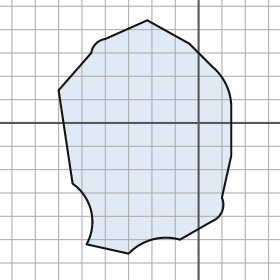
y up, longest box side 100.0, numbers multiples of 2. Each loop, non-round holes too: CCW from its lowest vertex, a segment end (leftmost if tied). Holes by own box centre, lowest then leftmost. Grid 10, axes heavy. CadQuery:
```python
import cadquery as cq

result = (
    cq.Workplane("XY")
    .moveTo(-30.0, -56.0)
    .threePointArc((-20.0, -50.0), (-8.0, -50.0))
    .lineTo(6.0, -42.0)
    .threePointArc((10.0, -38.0), (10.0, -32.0))
    .lineTo(14.0, -14.0)
    .lineTo(14.0, 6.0)
    .threePointArc((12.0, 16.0), (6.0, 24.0))
    .lineTo(-4.0, 34.0)
    .lineTo(-22.0, 44.0)
    .lineTo(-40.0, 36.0)
    .threePointArc((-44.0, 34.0), (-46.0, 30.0))
    .lineTo(-60.0, 14.0)
    .lineTo(-54.0, -26.0)
    .threePointArc((-46.0, -38.0), (-48.0, -52.0))
    .close()
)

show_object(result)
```